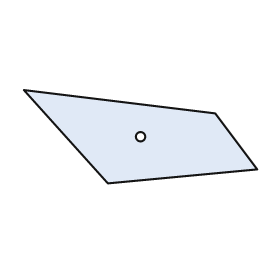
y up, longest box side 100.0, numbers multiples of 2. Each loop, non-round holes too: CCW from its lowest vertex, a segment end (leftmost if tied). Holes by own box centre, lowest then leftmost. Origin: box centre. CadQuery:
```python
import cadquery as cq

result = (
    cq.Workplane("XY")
    .moveTo(-14.0, -20.0)
    .lineTo(50.0, -14.0)
    .lineTo(32.0, 10.0)
    .lineTo(-50.0, 20.0)
    .close()
    .moveTo(0.0, 0.0)
    .circle(2.0)
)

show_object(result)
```